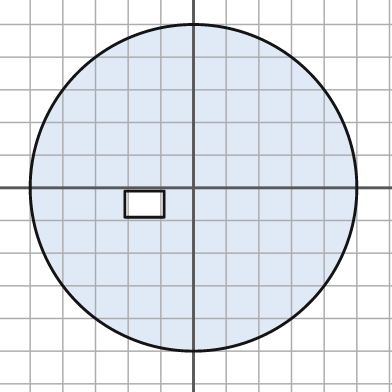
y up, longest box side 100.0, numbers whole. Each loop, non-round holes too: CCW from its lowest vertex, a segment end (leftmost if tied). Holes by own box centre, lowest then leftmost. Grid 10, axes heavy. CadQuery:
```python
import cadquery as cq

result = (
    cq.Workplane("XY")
    .moveTo(0.0, 0.0)
    .circle(50.0)
    .moveTo(-21.0, -9.0)
    .lineTo(-9.0, -9.0)
    .lineTo(-9.0, -1.0)
    .lineTo(-21.0, -1.0)
    .close()
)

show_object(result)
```